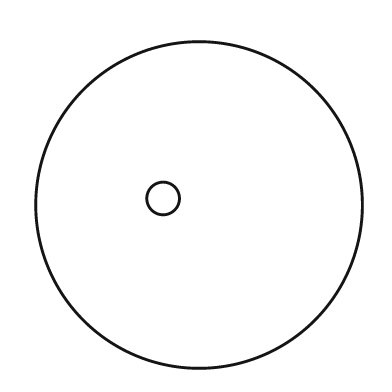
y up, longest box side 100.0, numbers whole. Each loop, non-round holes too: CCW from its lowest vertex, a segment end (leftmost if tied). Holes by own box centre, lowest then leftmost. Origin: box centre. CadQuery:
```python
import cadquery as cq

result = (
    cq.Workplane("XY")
    .moveTo(0.0, 0.0)
    .circle(50.0)
    .moveTo(-11.0, 2.0)
    .circle(5.0)
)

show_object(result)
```